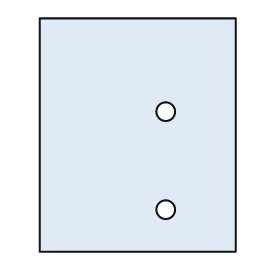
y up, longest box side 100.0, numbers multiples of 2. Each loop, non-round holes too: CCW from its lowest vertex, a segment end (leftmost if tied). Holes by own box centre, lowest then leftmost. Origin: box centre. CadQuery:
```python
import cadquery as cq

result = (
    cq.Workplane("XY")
    .moveTo(-42.0, -50.0)
    .lineTo(42.0, -50.0)
    .lineTo(42.0, 50.0)
    .lineTo(-42.0, 50.0)
    .close()
    .moveTo(12.0, -32.0)
    .circle(4.0)
    .moveTo(12.0, 10.0)
    .circle(4.0)
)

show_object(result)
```